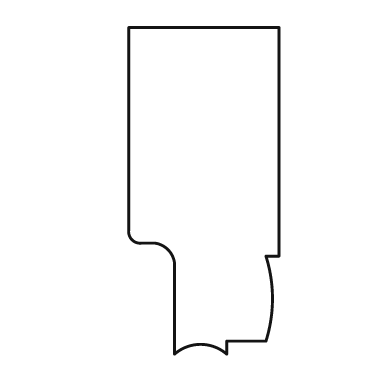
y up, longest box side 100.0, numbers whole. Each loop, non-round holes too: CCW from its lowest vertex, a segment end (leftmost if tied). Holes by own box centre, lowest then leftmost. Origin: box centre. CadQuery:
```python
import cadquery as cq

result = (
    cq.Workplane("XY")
    .moveTo(-9.0, -50.0)
    .threePointArc((-1.0, -47.0), (7.0, -50.0))
    .lineTo(7.0, -46.0)
    .lineTo(19.0, -46.0)
    .threePointArc((21.0, -33.0), (19.0, -20.0))
    .lineTo(23.0, -20.0)
    .lineTo(23.0, 50.0)
    .lineTo(-23.0, 50.0)
    .lineTo(-23.0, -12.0)
    .threePointArc((-22.0, -15.0), (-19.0, -16.0))
    .lineTo(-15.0, -16.0)
    .threePointArc((-11.0, -18.0), (-9.0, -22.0))
    .close()
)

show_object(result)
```